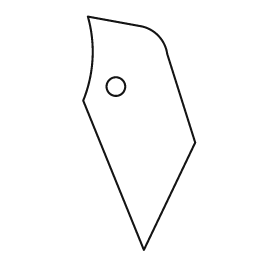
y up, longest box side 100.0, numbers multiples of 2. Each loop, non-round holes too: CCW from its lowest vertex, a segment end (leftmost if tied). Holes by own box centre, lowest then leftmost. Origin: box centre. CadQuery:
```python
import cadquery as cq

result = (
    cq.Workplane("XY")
    .moveTo(2.0, -50.0)
    .lineTo(24.0, -4.0)
    .lineTo(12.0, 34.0)
    .threePointArc((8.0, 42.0), (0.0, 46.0))
    .lineTo(-22.0, 50.0)
    .threePointArc((-20.0, 32.0), (-24.0, 14.0))
    .close()
    .moveTo(-10.0, 20.0)
    .circle(4.0)
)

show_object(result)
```